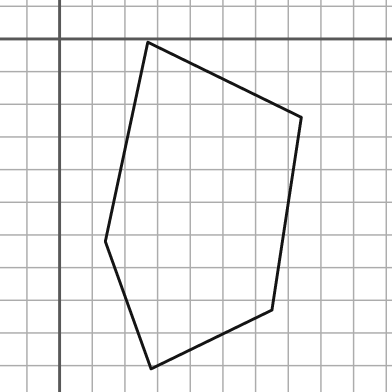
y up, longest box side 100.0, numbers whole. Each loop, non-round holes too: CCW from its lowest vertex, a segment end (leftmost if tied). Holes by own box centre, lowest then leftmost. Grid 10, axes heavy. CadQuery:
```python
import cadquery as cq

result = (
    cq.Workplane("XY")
    .moveTo(28.0, -101.0)
    .lineTo(65.0, -83.0)
    .lineTo(74.0, -24.0)
    .lineTo(27.0, -1.0)
    .lineTo(14.0, -62.0)
    .close()
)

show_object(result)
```